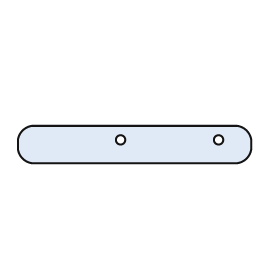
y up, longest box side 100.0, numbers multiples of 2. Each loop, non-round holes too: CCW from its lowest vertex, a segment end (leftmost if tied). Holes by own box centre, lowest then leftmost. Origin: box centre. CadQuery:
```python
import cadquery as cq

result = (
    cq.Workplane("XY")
    .moveTo(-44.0, -8.0)
    .lineTo(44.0, -8.0)
    .threePointArc((48.0, -6.0), (50.0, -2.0))
    .lineTo(50.0, 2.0)
    .threePointArc((48.0, 6.0), (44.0, 8.0))
    .lineTo(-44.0, 8.0)
    .threePointArc((-48.0, 6.0), (-50.0, 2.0))
    .lineTo(-50.0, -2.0)
    .threePointArc((-48.0, -6.0), (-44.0, -8.0))
    .close()
    .moveTo(-6.0, 2.0)
    .circle(2.0)
    .moveTo(36.0, 2.0)
    .circle(2.0)
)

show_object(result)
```